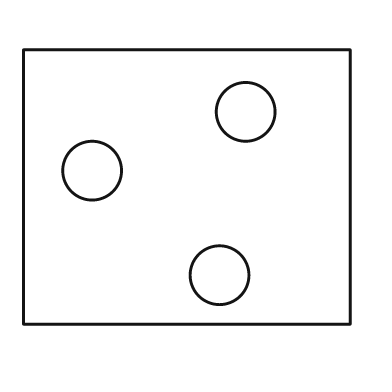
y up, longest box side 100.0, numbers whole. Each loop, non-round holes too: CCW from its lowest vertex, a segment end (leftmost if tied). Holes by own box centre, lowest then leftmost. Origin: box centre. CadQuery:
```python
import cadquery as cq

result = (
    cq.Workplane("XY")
    .moveTo(-50.0, -42.0)
    .lineTo(50.0, -42.0)
    .lineTo(50.0, 42.0)
    .lineTo(-50.0, 42.0)
    .close()
    .moveTo(10.0, -27.0)
    .circle(9.0)
    .moveTo(-29.0, 5.0)
    .circle(9.0)
    .moveTo(18.0, 23.0)
    .circle(9.0)
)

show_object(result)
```